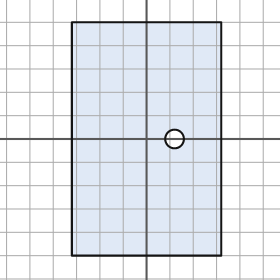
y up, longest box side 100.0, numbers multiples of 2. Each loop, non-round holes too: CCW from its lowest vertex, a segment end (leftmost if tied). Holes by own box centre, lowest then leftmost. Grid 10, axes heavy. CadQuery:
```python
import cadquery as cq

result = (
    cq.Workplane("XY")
    .moveTo(-32.0, -50.0)
    .lineTo(32.0, -50.0)
    .lineTo(32.0, 50.0)
    .lineTo(-32.0, 50.0)
    .close()
    .moveTo(12.0, 0.0)
    .circle(4.0)
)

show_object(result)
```